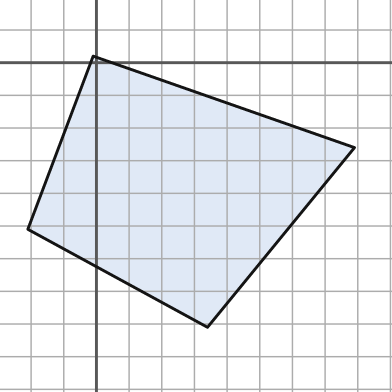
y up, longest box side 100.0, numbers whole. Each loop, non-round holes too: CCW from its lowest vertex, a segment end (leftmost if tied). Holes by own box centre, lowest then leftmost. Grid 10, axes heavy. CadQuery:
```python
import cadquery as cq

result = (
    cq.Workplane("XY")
    .moveTo(34.0, -81.0)
    .lineTo(79.0, -26.0)
    .lineTo(-1.0, 2.0)
    .lineTo(-21.0, -51.0)
    .close()
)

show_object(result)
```